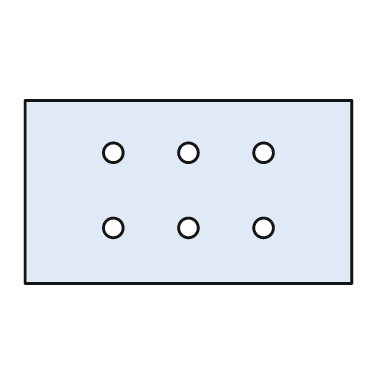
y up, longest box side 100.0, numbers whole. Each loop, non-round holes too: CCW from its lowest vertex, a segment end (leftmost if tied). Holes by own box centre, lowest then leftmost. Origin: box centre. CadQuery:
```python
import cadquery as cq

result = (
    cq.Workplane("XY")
    .moveTo(-50.0, -28.0)
    .lineTo(50.0, -28.0)
    .lineTo(50.0, 28.0)
    .lineTo(-50.0, 28.0)
    .close()
    .moveTo(-23.0, -11.0)
    .circle(3.0)
    .moveTo(0.0, -11.0)
    .circle(3.0)
    .moveTo(23.0, -11.0)
    .circle(3.0)
    .moveTo(-23.0, 12.0)
    .circle(3.0)
    .moveTo(0.0, 12.0)
    .circle(3.0)
    .moveTo(23.0, 12.0)
    .circle(3.0)
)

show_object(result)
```